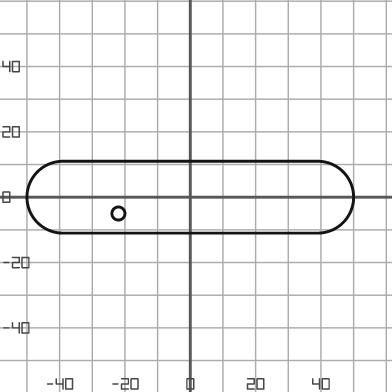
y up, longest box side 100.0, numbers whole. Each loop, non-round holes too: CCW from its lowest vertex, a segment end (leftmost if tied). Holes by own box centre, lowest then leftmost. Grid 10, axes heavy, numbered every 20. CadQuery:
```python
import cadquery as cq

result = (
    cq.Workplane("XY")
    .moveTo(-39.0, -11.0)
    .lineTo(39.0, -11.0)
    .threePointArc((50.0, 0.0), (39.0, 11.0))
    .lineTo(-39.0, 11.0)
    .threePointArc((-50.0, 0.0), (-39.0, -11.0))
    .close()
    .moveTo(-22.0, -5.0)
    .circle(2.0)
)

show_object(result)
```